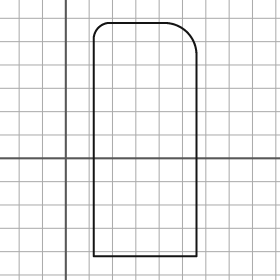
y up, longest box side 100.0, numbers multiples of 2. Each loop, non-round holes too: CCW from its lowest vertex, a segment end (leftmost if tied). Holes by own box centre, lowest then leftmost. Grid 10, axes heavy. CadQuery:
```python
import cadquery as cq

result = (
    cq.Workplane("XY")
    .moveTo(12.0, -42.0)
    .lineTo(56.0, -42.0)
    .lineTo(56.0, 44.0)
    .threePointArc((52.0, 54.0), (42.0, 58.0))
    .lineTo(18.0, 58.0)
    .threePointArc((14.0, 56.0), (12.0, 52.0))
    .close()
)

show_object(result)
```